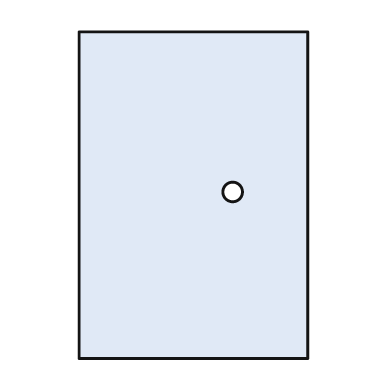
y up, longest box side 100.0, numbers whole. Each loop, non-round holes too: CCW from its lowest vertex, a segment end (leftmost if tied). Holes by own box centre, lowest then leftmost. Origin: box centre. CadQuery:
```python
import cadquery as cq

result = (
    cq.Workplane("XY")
    .moveTo(-35.0, -50.0)
    .lineTo(35.0, -50.0)
    .lineTo(35.0, 50.0)
    .lineTo(-35.0, 50.0)
    .close()
    .moveTo(12.0, 1.0)
    .circle(3.0)
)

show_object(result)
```